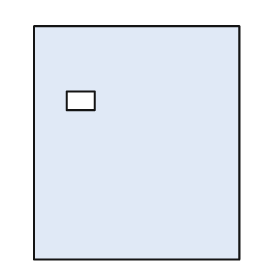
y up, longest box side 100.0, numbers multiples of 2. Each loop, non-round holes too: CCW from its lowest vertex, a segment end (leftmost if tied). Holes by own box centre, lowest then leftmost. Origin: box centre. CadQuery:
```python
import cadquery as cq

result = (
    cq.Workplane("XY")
    .moveTo(-44.0, -50.0)
    .lineTo(44.0, -50.0)
    .lineTo(44.0, 50.0)
    .lineTo(-44.0, 50.0)
    .close()
    .moveTo(-30.0, 14.0)
    .lineTo(-18.0, 14.0)
    .lineTo(-18.0, 22.0)
    .lineTo(-30.0, 22.0)
    .close()
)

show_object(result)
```